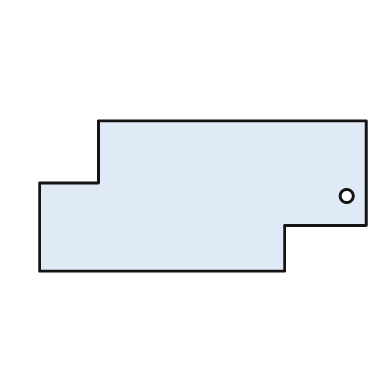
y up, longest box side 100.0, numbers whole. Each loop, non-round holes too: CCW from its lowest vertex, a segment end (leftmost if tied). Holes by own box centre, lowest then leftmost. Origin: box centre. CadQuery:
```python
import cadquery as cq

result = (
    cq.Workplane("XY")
    .moveTo(-50.0, -23.0)
    .lineTo(25.0, -23.0)
    .lineTo(25.0, -9.0)
    .lineTo(50.0, -9.0)
    .lineTo(50.0, 23.0)
    .lineTo(-32.0, 23.0)
    .lineTo(-32.0, 4.0)
    .lineTo(-50.0, 4.0)
    .close()
    .moveTo(44.0, 0.0)
    .circle(2.0)
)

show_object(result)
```